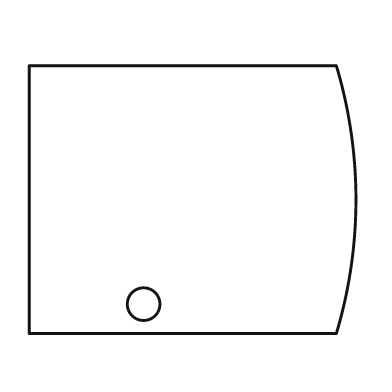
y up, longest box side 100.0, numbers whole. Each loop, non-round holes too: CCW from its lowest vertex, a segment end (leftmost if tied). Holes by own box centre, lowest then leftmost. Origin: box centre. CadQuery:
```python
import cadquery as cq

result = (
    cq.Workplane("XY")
    .moveTo(-50.0, -41.0)
    .lineTo(44.0, -41.0)
    .threePointArc((50.0, 0.0), (44.0, 41.0))
    .lineTo(-50.0, 41.0)
    .close()
    .moveTo(-15.0, -32.0)
    .circle(5.0)
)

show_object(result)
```